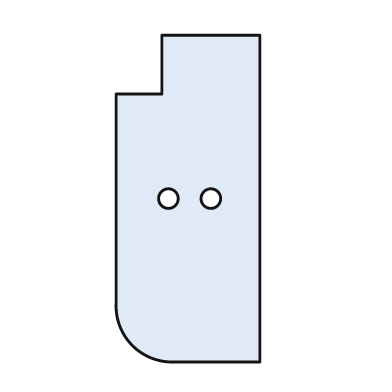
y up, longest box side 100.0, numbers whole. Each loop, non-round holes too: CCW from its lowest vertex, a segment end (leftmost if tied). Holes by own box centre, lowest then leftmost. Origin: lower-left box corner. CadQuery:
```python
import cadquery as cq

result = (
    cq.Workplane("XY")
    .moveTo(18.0, 0.0)
    .lineTo(44.0, 0.0)
    .lineTo(44.0, 100.0)
    .lineTo(14.0, 100.0)
    .lineTo(14.0, 82.0)
    .lineTo(0.0, 82.0)
    .lineTo(0.0, 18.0)
    .threePointArc((5.0, 5.0), (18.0, 0.0))
    .close()
    .moveTo(16.0, 50.0)
    .circle(3.0)
    .moveTo(29.0, 50.0)
    .circle(3.0)
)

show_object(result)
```